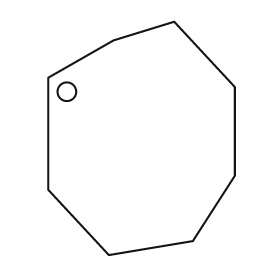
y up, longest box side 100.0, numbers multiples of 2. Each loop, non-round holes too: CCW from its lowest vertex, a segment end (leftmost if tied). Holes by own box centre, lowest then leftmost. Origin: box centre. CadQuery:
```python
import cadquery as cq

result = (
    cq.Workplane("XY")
    .moveTo(-14.0, -50.0)
    .lineTo(22.0, -44.0)
    .lineTo(40.0, -16.0)
    .lineTo(40.0, 22.0)
    .lineTo(14.0, 50.0)
    .lineTo(-12.0, 42.0)
    .lineTo(-40.0, 26.0)
    .lineTo(-40.0, -22.0)
    .close()
    .moveTo(-32.0, 20.0)
    .circle(4.0)
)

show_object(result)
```